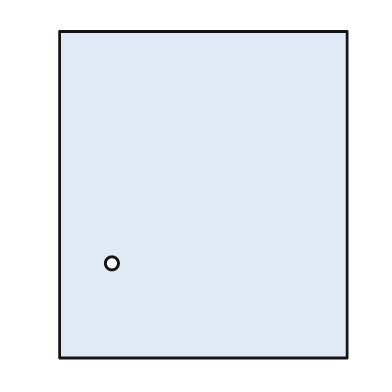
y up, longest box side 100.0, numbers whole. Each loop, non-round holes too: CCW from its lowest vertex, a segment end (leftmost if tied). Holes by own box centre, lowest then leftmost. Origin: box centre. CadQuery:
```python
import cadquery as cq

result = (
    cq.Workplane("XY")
    .moveTo(-44.0, -50.0)
    .lineTo(44.0, -50.0)
    .lineTo(44.0, 50.0)
    .lineTo(-44.0, 50.0)
    .close()
    .moveTo(-28.0, -21.0)
    .circle(2.0)
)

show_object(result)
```